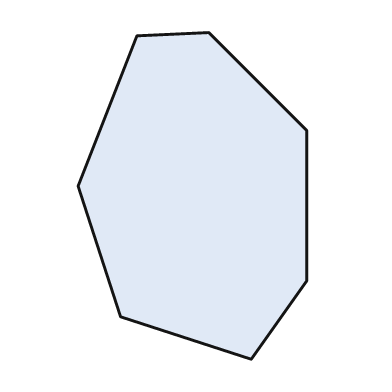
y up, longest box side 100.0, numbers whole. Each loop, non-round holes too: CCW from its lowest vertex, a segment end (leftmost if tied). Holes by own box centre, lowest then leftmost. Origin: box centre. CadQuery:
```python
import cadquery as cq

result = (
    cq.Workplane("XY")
    .moveTo(18.0, -50.0)
    .lineTo(35.0, -26.0)
    .lineTo(35.0, 20.0)
    .lineTo(5.0, 50.0)
    .lineTo(-17.0, 49.0)
    .lineTo(-35.0, 3.0)
    .lineTo(-22.0, -37.0)
    .close()
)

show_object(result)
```